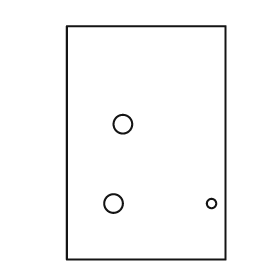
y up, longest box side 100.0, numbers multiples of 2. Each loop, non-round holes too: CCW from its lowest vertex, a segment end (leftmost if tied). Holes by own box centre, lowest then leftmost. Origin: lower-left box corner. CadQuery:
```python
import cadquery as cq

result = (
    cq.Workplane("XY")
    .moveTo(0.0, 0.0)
    .lineTo(68.0, 0.0)
    .lineTo(68.0, 100.0)
    .lineTo(0.0, 100.0)
    .close()
    .moveTo(20.0, 24.0)
    .circle(4.0)
    .moveTo(62.0, 24.0)
    .circle(2.0)
    .moveTo(24.0, 58.0)
    .circle(4.0)
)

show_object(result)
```